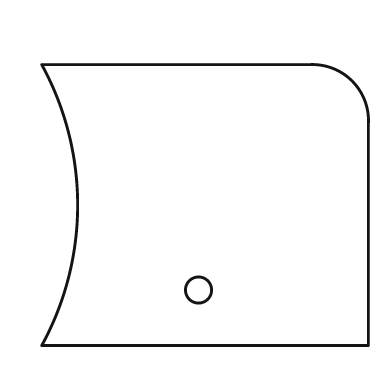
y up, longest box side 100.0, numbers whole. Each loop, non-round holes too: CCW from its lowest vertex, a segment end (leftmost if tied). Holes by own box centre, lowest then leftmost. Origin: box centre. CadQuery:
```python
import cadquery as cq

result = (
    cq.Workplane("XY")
    .moveTo(-50.0, -43.0)
    .lineTo(50.0, -43.0)
    .lineTo(50.0, 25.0)
    .threePointArc((45.0, 38.0), (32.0, 43.0))
    .lineTo(-50.0, 43.0)
    .threePointArc((-39.0, 0.0), (-50.0, -43.0))
    .close()
    .moveTo(-2.0, -26.0)
    .circle(4.0)
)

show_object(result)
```